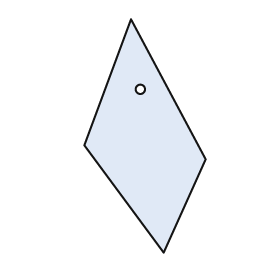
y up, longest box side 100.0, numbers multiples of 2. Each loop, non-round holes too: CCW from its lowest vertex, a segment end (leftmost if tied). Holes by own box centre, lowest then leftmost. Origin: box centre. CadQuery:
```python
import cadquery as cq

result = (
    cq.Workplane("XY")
    .moveTo(8.0, -50.0)
    .lineTo(26.0, -10.0)
    .lineTo(-6.0, 50.0)
    .lineTo(-26.0, -4.0)
    .close()
    .moveTo(-2.0, 20.0)
    .circle(2.0)
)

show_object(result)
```